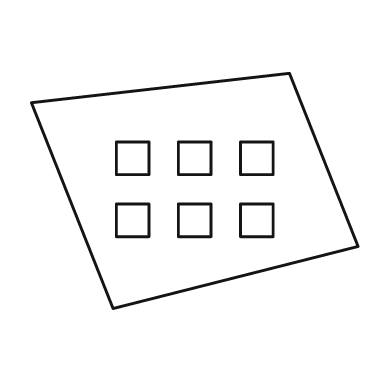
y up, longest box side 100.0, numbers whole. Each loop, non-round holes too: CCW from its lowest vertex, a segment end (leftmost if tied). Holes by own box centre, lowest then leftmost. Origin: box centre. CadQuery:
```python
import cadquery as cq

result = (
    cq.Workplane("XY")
    .moveTo(-25.0, -36.0)
    .lineTo(50.0, -17.0)
    .lineTo(29.0, 36.0)
    .lineTo(-50.0, 27.0)
    .close()
    .moveTo(-24.0, -14.0)
    .lineTo(-14.0, -14.0)
    .lineTo(-14.0, -4.0)
    .lineTo(-24.0, -4.0)
    .close()
    .moveTo(-5.0, -14.0)
    .lineTo(5.0, -14.0)
    .lineTo(5.0, -4.0)
    .lineTo(-5.0, -4.0)
    .close()
    .moveTo(14.0, -14.0)
    .lineTo(24.0, -14.0)
    .lineTo(24.0, -4.0)
    .lineTo(14.0, -4.0)
    .close()
    .moveTo(-24.0, 5.0)
    .lineTo(-14.0, 5.0)
    .lineTo(-14.0, 15.0)
    .lineTo(-24.0, 15.0)
    .close()
    .moveTo(-5.0, 5.0)
    .lineTo(5.0, 5.0)
    .lineTo(5.0, 15.0)
    .lineTo(-5.0, 15.0)
    .close()
    .moveTo(14.0, 5.0)
    .lineTo(24.0, 5.0)
    .lineTo(24.0, 15.0)
    .lineTo(14.0, 15.0)
    .close()
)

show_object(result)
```